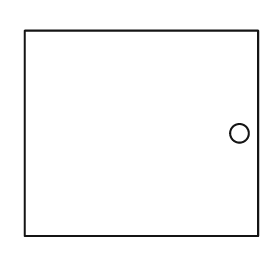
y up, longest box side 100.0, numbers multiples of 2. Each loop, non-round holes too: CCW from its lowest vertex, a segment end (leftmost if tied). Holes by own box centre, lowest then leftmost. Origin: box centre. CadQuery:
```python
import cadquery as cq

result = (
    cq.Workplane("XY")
    .moveTo(-50.0, -44.0)
    .lineTo(50.0, -44.0)
    .lineTo(50.0, 44.0)
    .lineTo(-50.0, 44.0)
    .close()
    .moveTo(42.0, 0.0)
    .circle(4.0)
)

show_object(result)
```